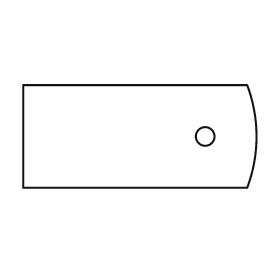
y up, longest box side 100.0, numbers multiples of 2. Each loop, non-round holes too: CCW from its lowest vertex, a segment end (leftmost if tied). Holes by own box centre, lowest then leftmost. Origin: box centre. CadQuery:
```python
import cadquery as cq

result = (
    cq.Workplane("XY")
    .moveTo(-50.0, -22.0)
    .lineTo(46.0, -22.0)
    .threePointArc((50.0, 0.0), (46.0, 22.0))
    .lineTo(-50.0, 22.0)
    .close()
    .moveTo(28.0, 0.0)
    .circle(4.0)
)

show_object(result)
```